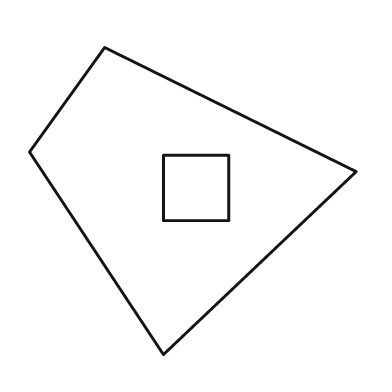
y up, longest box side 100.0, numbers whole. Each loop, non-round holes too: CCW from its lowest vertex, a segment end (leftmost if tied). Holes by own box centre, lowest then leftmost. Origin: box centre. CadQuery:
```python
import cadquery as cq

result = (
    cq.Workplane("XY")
    .moveTo(-9.0, -47.0)
    .lineTo(50.0, 9.0)
    .lineTo(-27.0, 47.0)
    .lineTo(-50.0, 15.0)
    .close()
    .moveTo(-9.0, -6.0)
    .lineTo(11.0, -6.0)
    .lineTo(11.0, 14.0)
    .lineTo(-9.0, 14.0)
    .close()
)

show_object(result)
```